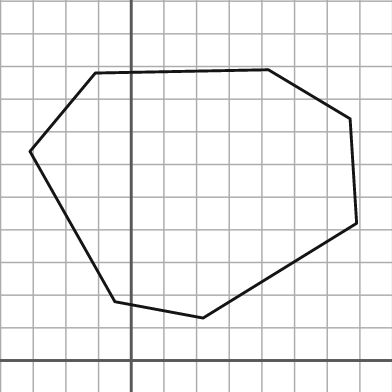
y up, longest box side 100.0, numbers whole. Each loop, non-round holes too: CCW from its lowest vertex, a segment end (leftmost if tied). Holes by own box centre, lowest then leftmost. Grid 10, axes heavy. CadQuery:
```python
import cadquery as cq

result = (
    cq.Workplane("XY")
    .moveTo(22.0, 13.0)
    .lineTo(69.0, 42.0)
    .lineTo(67.0, 74.0)
    .lineTo(42.0, 89.0)
    .lineTo(-11.0, 88.0)
    .lineTo(-31.0, 64.0)
    .lineTo(-5.0, 18.0)
    .close()
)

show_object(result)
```